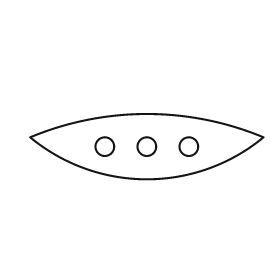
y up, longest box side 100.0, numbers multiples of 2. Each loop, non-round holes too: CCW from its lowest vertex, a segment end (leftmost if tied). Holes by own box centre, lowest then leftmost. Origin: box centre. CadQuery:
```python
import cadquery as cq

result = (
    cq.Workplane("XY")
    .moveTo(-50.0, 4.0)
    .threePointArc((0.0, -14.0), (50.0, 4.0))
    .threePointArc((0.0, 14.0), (-50.0, 4.0))
    .close()
    .moveTo(-18.0, 0.0)
    .circle(4.0)
    .moveTo(0.0, 0.0)
    .circle(4.0)
    .moveTo(18.0, 0.0)
    .circle(4.0)
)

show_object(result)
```